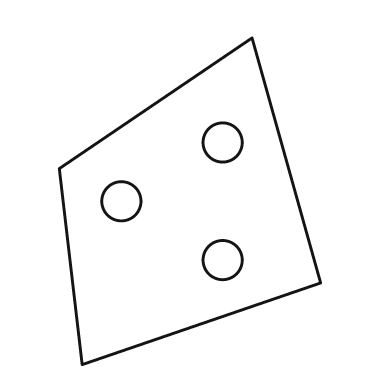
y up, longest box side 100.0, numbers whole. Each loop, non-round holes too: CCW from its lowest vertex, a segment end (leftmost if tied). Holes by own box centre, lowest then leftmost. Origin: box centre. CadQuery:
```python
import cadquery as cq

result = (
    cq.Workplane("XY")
    .moveTo(-33.0, -50.0)
    .lineTo(40.0, -25.0)
    .lineTo(19.0, 50.0)
    .lineTo(-40.0, 10.0)
    .close()
    .moveTo(10.0, -18.0)
    .circle(6.0)
    .moveTo(-21.0, 0.0)
    .circle(6.0)
    .moveTo(10.0, 18.0)
    .circle(6.0)
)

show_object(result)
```